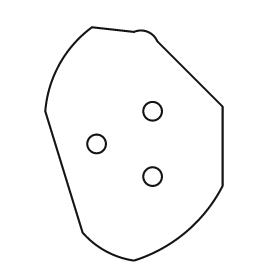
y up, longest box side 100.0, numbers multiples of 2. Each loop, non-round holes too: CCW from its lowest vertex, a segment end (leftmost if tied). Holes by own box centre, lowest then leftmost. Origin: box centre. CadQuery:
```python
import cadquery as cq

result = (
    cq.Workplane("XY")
    .moveTo(0.0, -50.0)
    .threePointArc((22.0, -38.0), (38.0, -18.0))
    .lineTo(38.0, 16.0)
    .lineTo(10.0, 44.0)
    .threePointArc((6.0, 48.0), (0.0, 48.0))
    .lineTo(-18.0, 50.0)
    .threePointArc((-32.0, 34.0), (-38.0, 14.0))
    .lineTo(-22.0, -38.0)
    .threePointArc((-12.0, -46.0), (0.0, -50.0))
    .close()
    .moveTo(8.0, -14.0)
    .circle(4.0)
    .moveTo(-16.0, 0.0)
    .circle(4.0)
    .moveTo(8.0, 14.0)
    .circle(4.0)
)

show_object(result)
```